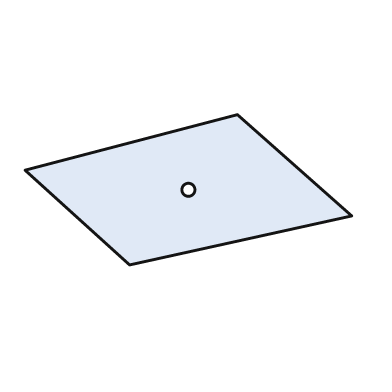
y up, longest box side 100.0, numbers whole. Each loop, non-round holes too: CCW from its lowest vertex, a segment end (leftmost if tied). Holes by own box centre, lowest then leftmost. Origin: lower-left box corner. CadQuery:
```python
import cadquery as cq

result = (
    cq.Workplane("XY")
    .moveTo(32.0, 0.0)
    .lineTo(100.0, 15.0)
    .lineTo(65.0, 46.0)
    .lineTo(0.0, 29.0)
    .close()
    .moveTo(50.0, 23.0)
    .circle(2.0)
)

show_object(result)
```